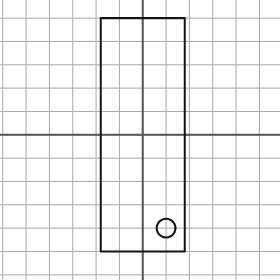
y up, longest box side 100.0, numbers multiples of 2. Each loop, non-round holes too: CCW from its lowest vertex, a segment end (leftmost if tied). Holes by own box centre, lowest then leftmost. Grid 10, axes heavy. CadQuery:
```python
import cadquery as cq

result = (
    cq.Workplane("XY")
    .moveTo(-18.0, -50.0)
    .lineTo(18.0, -50.0)
    .lineTo(18.0, 50.0)
    .lineTo(-18.0, 50.0)
    .close()
    .moveTo(10.0, -40.0)
    .circle(4.0)
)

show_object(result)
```